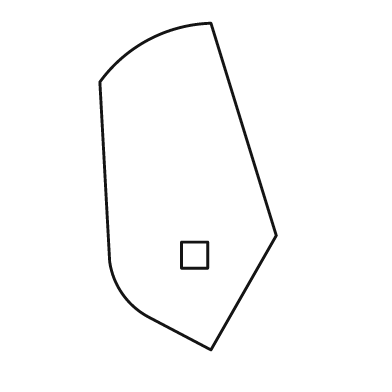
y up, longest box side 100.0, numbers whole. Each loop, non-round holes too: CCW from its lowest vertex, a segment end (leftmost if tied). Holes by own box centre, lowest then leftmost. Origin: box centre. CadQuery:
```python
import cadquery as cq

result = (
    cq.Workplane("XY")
    .moveTo(7.0, -50.0)
    .lineTo(27.0, -15.0)
    .lineTo(7.0, 50.0)
    .threePointArc((-12.0, 45.0), (-27.0, 32.0))
    .lineTo(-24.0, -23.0)
    .threePointArc((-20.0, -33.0), (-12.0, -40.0))
    .close()
    .moveTo(-2.0, -25.0)
    .lineTo(6.0, -25.0)
    .lineTo(6.0, -17.0)
    .lineTo(-2.0, -17.0)
    .close()
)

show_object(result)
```